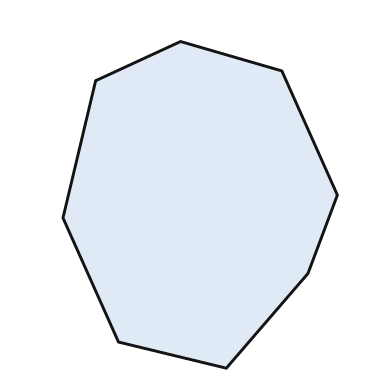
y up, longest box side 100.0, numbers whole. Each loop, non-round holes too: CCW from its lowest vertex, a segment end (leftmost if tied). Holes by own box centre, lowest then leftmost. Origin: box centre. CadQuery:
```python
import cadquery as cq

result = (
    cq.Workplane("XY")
    .moveTo(8.0, -50.0)
    .lineTo(33.0, -21.0)
    .lineTo(42.0, 3.0)
    .lineTo(25.0, 41.0)
    .lineTo(-6.0, 50.0)
    .lineTo(-32.0, 38.0)
    .lineTo(-42.0, -4.0)
    .lineTo(-25.0, -42.0)
    .close()
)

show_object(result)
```